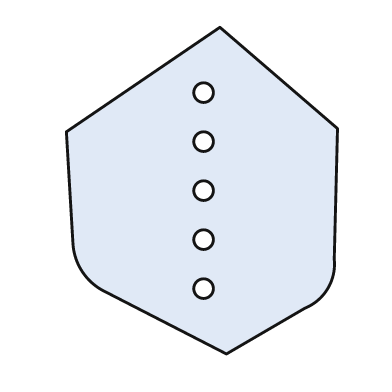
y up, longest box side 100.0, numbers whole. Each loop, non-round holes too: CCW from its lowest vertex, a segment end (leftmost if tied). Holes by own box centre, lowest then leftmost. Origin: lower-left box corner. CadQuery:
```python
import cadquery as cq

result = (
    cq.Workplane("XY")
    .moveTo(49.0, 0.0)
    .lineTo(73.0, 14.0)
    .threePointArc((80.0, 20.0), (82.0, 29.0))
    .lineTo(83.0, 69.0)
    .lineTo(47.0, 100.0)
    .lineTo(0.0, 68.0)
    .lineTo(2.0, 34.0)
    .threePointArc((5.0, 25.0), (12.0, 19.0))
    .close()
    .moveTo(42.0, 20.0)
    .circle(3.0)
    .moveTo(42.0, 35.0)
    .circle(3.0)
    .moveTo(42.0, 50.0)
    .circle(3.0)
    .moveTo(42.0, 65.0)
    .circle(3.0)
    .moveTo(42.0, 80.0)
    .circle(3.0)
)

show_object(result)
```